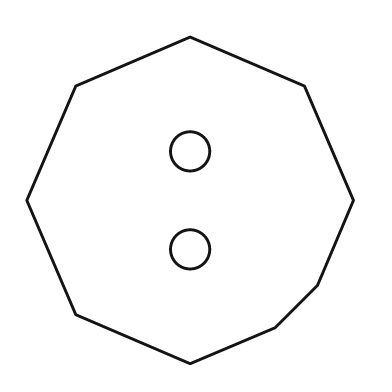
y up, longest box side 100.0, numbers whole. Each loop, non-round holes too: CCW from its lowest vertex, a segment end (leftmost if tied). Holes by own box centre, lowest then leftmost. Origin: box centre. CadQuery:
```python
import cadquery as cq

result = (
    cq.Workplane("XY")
    .moveTo(0.0, -50.0)
    .lineTo(26.0, -39.0)
    .lineTo(39.0, -26.0)
    .lineTo(50.0, 0.0)
    .lineTo(35.0, 35.0)
    .lineTo(0.0, 50.0)
    .lineTo(-35.0, 35.0)
    .lineTo(-50.0, 0.0)
    .lineTo(-35.0, -35.0)
    .close()
    .moveTo(0.0, -15.0)
    .circle(6.0)
    .moveTo(0.0, 15.0)
    .circle(6.0)
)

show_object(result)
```